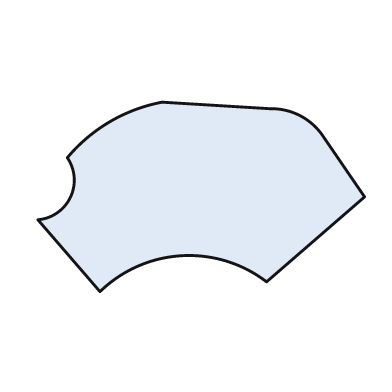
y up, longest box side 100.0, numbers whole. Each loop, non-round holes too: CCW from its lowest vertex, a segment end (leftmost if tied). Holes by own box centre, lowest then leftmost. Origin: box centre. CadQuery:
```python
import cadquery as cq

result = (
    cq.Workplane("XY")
    .moveTo(-31.0, -29.0)
    .threePointArc((-6.0, -18.0), (20.0, -26.0))
    .lineTo(50.0, 0.0)
    .lineTo(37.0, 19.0)
    .threePointArc((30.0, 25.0), (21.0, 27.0))
    .lineTo(-12.0, 29.0)
    .threePointArc((-28.0, 23.0), (-41.0, 12.0))
    .threePointArc((-40.0, 0.0), (-50.0, -7.0))
    .close()
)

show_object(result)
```